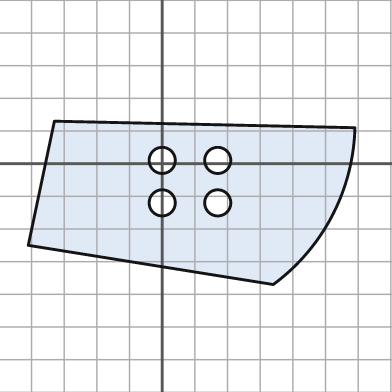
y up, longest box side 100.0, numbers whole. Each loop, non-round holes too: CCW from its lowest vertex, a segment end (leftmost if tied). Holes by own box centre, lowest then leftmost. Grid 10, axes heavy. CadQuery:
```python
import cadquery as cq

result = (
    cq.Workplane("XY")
    .moveTo(34.0, -37.0)
    .threePointArc((52.0, -16.0), (59.0, 11.0))
    .lineTo(-33.0, 13.0)
    .lineTo(-41.0, -25.0)
    .close()
    .moveTo(0.0, -12.0)
    .circle(4.0)
    .moveTo(17.0, -12.0)
    .circle(4.0)
    .moveTo(0.0, 1.0)
    .circle(4.0)
    .moveTo(17.0, 1.0)
    .circle(4.0)
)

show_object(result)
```